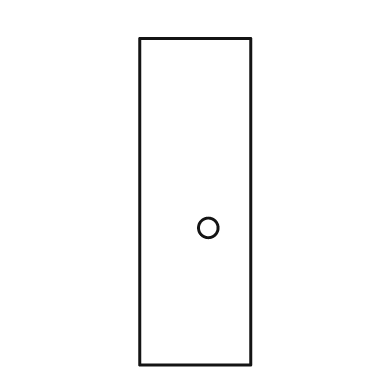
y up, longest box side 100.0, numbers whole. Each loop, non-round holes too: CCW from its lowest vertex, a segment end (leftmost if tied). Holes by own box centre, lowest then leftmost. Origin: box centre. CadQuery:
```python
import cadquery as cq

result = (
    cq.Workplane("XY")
    .moveTo(-17.0, -50.0)
    .lineTo(17.0, -50.0)
    .lineTo(17.0, 50.0)
    .lineTo(-17.0, 50.0)
    .close()
    .moveTo(4.0, -8.0)
    .circle(3.0)
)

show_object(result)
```